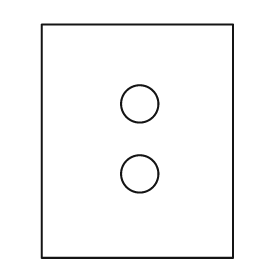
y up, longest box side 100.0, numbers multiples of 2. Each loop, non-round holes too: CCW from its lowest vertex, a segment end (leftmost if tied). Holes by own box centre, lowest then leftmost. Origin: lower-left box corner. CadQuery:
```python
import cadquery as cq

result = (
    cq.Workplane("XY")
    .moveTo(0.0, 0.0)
    .lineTo(82.0, 0.0)
    .lineTo(82.0, 100.0)
    .lineTo(0.0, 100.0)
    .close()
    .moveTo(42.0, 36.0)
    .circle(8.0)
    .moveTo(42.0, 66.0)
    .circle(8.0)
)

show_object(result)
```